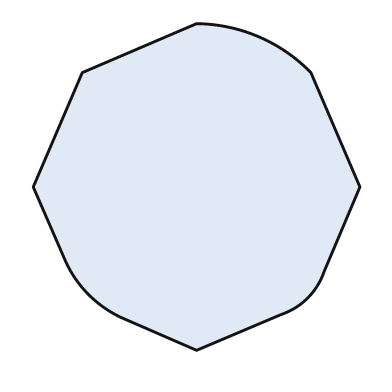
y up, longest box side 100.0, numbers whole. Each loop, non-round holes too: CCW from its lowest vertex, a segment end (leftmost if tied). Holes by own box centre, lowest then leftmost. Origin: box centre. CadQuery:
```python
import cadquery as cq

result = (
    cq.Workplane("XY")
    .moveTo(0.0, -50.0)
    .lineTo(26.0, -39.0)
    .threePointArc((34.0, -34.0), (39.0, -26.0))
    .lineTo(50.0, 0.0)
    .lineTo(35.0, 35.0)
    .threePointArc((19.0, 46.0), (0.0, 50.0))
    .lineTo(-35.0, 35.0)
    .lineTo(-50.0, 0.0)
    .lineTo(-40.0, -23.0)
    .threePointArc((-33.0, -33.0), (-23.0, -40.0))
    .close()
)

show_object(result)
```